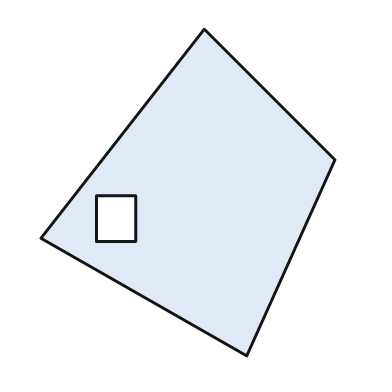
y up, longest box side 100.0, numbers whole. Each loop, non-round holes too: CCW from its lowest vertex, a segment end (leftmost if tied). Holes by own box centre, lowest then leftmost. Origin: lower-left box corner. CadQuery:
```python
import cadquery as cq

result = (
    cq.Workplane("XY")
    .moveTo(63.0, 0.0)
    .lineTo(90.0, 60.0)
    .lineTo(50.0, 100.0)
    .lineTo(0.0, 36.0)
    .close()
    .moveTo(17.0, 35.0)
    .lineTo(29.0, 35.0)
    .lineTo(29.0, 49.0)
    .lineTo(17.0, 49.0)
    .close()
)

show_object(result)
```